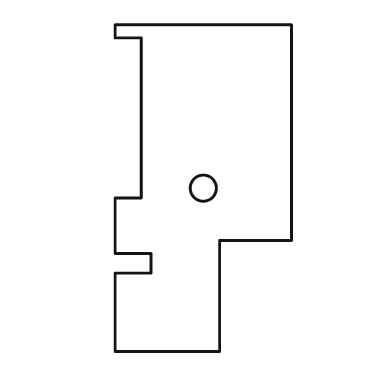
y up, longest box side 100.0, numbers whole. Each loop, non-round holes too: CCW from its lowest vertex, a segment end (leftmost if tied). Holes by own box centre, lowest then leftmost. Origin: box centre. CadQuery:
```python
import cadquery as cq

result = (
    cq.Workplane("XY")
    .moveTo(-27.0, -50.0)
    .lineTo(5.0, -50.0)
    .lineTo(5.0, -16.0)
    .lineTo(27.0, -16.0)
    .lineTo(27.0, 50.0)
    .lineTo(-27.0, 50.0)
    .lineTo(-27.0, 46.0)
    .lineTo(-19.0, 46.0)
    .lineTo(-19.0, -3.0)
    .lineTo(-27.0, -3.0)
    .lineTo(-27.0, -20.0)
    .lineTo(-16.0, -20.0)
    .lineTo(-16.0, -26.0)
    .lineTo(-27.0, -26.0)
    .close()
    .moveTo(0.0, 0.0)
    .circle(4.0)
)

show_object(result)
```